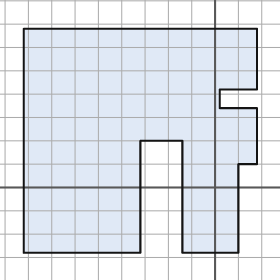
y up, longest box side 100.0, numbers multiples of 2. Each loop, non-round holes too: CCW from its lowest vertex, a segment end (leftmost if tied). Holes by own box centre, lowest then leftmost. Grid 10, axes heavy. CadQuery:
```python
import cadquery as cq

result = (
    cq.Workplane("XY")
    .moveTo(-82.0, -28.0)
    .lineTo(-32.0, -28.0)
    .lineTo(-32.0, 20.0)
    .lineTo(-14.0, 20.0)
    .lineTo(-14.0, -28.0)
    .lineTo(10.0, -28.0)
    .lineTo(10.0, 10.0)
    .lineTo(18.0, 10.0)
    .lineTo(18.0, 34.0)
    .lineTo(2.0, 34.0)
    .lineTo(2.0, 42.0)
    .lineTo(18.0, 42.0)
    .lineTo(18.0, 68.0)
    .lineTo(-82.0, 68.0)
    .close()
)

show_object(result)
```